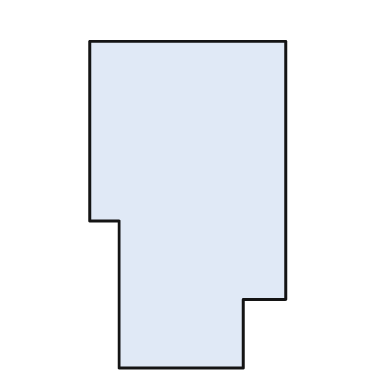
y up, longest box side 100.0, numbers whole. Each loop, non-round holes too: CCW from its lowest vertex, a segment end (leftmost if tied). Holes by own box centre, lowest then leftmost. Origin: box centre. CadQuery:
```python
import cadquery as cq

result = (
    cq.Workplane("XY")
    .moveTo(-21.0, -50.0)
    .lineTo(17.0, -50.0)
    .lineTo(17.0, -29.0)
    .lineTo(30.0, -29.0)
    .lineTo(30.0, 50.0)
    .lineTo(-30.0, 50.0)
    .lineTo(-30.0, -5.0)
    .lineTo(-21.0, -5.0)
    .close()
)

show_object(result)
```